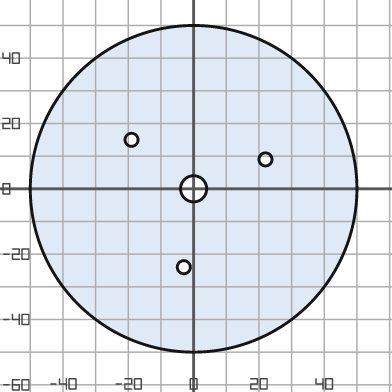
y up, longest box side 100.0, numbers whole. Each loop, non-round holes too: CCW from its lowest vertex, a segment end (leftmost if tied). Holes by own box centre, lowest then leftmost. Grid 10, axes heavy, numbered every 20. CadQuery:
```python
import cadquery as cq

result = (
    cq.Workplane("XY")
    .moveTo(0.0, 0.0)
    .circle(50.0)
    .moveTo(-3.0, -24.0)
    .circle(2.0)
    .moveTo(0.0, 0.0)
    .circle(4.0)
    .moveTo(22.0, 9.0)
    .circle(2.0)
    .moveTo(-19.0, 15.0)
    .circle(2.0)
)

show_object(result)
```